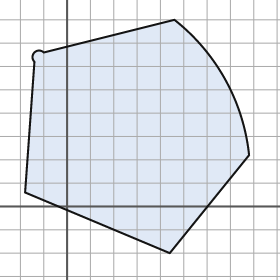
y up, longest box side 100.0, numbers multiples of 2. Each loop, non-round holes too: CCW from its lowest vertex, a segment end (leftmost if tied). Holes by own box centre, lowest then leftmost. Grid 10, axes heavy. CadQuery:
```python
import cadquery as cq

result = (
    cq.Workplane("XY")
    .moveTo(44.0, -20.0)
    .lineTo(78.0, 22.0)
    .threePointArc((68.0, 54.0), (46.0, 80.0))
    .lineTo(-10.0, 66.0)
    .threePointArc((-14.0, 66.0), (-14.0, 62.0))
    .lineTo(-18.0, 6.0)
    .close()
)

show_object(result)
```